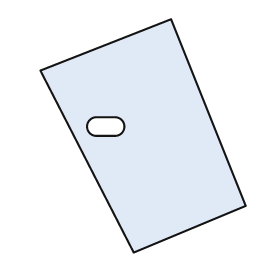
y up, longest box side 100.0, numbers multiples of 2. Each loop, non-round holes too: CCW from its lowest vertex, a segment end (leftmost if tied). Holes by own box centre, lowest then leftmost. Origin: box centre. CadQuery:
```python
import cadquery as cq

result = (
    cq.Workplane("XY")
    .moveTo(-4.0, -50.0)
    .lineTo(44.0, -30.0)
    .lineTo(12.0, 50.0)
    .lineTo(-44.0, 28.0)
    .close()
    .moveTo(-20.0, 0.0)
    .lineTo(-12.0, 0.0)
    .threePointArc((-8.0, 4.0), (-12.0, 8.0))
    .lineTo(-20.0, 8.0)
    .threePointArc((-24.0, 4.0), (-20.0, 0.0))
    .close()
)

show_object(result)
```